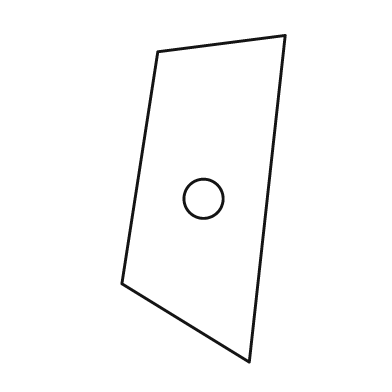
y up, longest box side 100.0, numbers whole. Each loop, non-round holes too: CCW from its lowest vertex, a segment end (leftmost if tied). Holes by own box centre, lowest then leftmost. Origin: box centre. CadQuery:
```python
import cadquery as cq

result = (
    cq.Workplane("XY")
    .moveTo(14.0, -50.0)
    .lineTo(25.0, 50.0)
    .lineTo(-14.0, 45.0)
    .lineTo(-25.0, -26.0)
    .close()
    .moveTo(0.0, 0.0)
    .circle(6.0)
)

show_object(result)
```